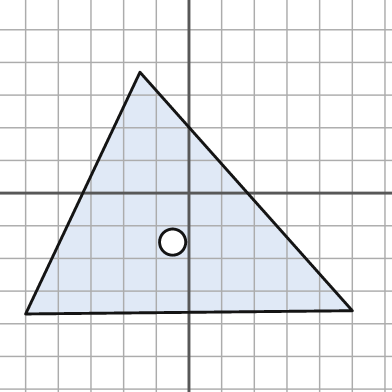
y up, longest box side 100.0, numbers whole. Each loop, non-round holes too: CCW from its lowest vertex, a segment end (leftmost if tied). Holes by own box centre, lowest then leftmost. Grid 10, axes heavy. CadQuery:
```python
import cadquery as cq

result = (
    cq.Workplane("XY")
    .moveTo(-50.0, -37.0)
    .lineTo(50.0, -36.0)
    .lineTo(-15.0, 37.0)
    .close()
    .moveTo(-5.0, -15.0)
    .circle(4.0)
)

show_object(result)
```